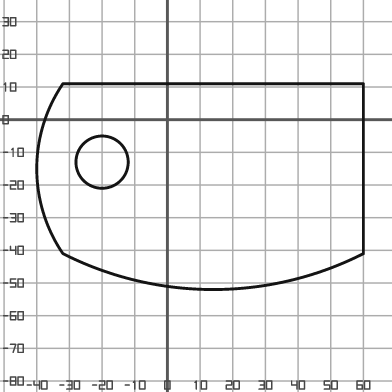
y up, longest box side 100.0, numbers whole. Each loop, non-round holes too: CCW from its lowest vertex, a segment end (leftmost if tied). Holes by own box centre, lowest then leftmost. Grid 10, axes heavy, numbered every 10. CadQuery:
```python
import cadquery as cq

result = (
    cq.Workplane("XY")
    .moveTo(-32.0, -41.0)
    .threePointArc((14.0, -52.0), (60.0, -41.0))
    .lineTo(60.0, 11.0)
    .lineTo(-32.0, 11.0)
    .threePointArc((-40.0, -15.0), (-32.0, -41.0))
    .close()
    .moveTo(-20.0, -13.0)
    .circle(8.0)
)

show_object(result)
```